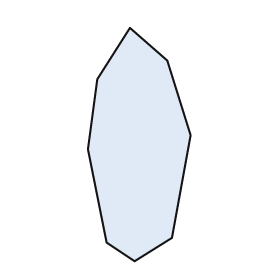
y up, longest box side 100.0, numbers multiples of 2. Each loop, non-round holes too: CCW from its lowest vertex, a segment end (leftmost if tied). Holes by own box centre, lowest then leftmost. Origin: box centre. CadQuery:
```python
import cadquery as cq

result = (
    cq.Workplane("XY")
    .moveTo(-2.0, -50.0)
    .lineTo(14.0, -40.0)
    .lineTo(22.0, 4.0)
    .lineTo(12.0, 36.0)
    .lineTo(-4.0, 50.0)
    .lineTo(-18.0, 28.0)
    .lineTo(-22.0, -2.0)
    .lineTo(-14.0, -42.0)
    .close()
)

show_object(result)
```